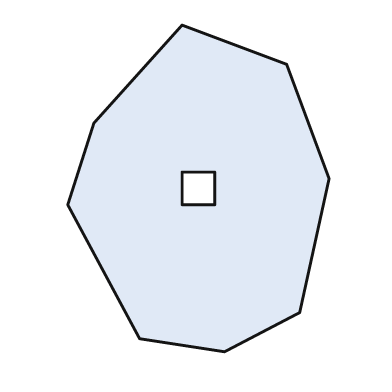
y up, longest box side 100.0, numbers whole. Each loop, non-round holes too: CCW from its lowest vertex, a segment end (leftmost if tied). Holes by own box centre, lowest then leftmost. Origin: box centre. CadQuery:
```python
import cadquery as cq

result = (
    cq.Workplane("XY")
    .moveTo(8.0, -50.0)
    .lineTo(31.0, -38.0)
    .lineTo(40.0, 3.0)
    .lineTo(27.0, 38.0)
    .lineTo(-5.0, 50.0)
    .lineTo(-32.0, 20.0)
    .lineTo(-40.0, -5.0)
    .lineTo(-18.0, -46.0)
    .close()
    .moveTo(-5.0, -5.0)
    .lineTo(5.0, -5.0)
    .lineTo(5.0, 5.0)
    .lineTo(-5.0, 5.0)
    .close()
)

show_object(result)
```